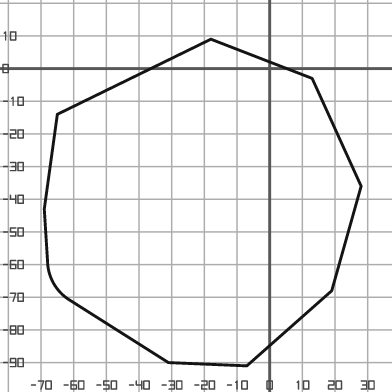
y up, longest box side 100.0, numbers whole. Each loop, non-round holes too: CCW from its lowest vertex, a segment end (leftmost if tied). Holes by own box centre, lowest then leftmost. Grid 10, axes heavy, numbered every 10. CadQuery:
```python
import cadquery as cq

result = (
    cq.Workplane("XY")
    .moveTo(-7.0, -91.0)
    .lineTo(19.0, -68.0)
    .lineTo(28.0, -36.0)
    .lineTo(13.0, -3.0)
    .lineTo(-18.0, 9.0)
    .lineTo(-65.0, -14.0)
    .lineTo(-69.0, -43.0)
    .lineTo(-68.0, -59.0)
    .threePointArc((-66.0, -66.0), (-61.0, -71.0))
    .lineTo(-31.0, -90.0)
    .close()
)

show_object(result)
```